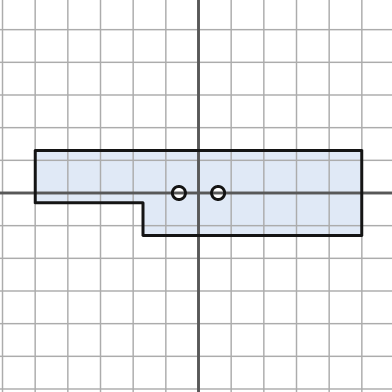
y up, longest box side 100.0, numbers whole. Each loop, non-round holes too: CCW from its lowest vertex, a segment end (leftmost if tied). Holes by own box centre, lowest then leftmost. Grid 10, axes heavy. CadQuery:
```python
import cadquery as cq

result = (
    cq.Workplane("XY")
    .moveTo(-17.0, -13.0)
    .lineTo(50.0, -13.0)
    .lineTo(50.0, 13.0)
    .lineTo(-50.0, 13.0)
    .lineTo(-50.0, -3.0)
    .lineTo(-17.0, -3.0)
    .close()
    .moveTo(-6.0, 0.0)
    .circle(2.0)
    .moveTo(6.0, 0.0)
    .circle(2.0)
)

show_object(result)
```